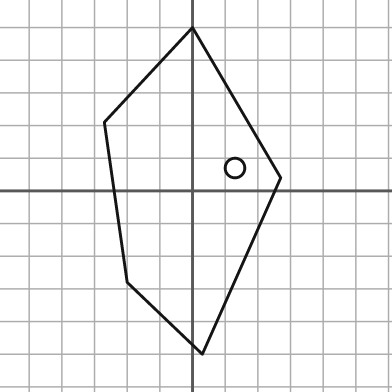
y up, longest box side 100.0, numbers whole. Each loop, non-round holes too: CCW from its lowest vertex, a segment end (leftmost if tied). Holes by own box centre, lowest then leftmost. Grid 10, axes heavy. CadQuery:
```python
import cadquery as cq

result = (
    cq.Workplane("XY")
    .moveTo(3.0, -50.0)
    .lineTo(27.0, 4.0)
    .lineTo(0.0, 50.0)
    .lineTo(-27.0, 21.0)
    .lineTo(-20.0, -28.0)
    .close()
    .moveTo(13.0, 7.0)
    .circle(3.0)
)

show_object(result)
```